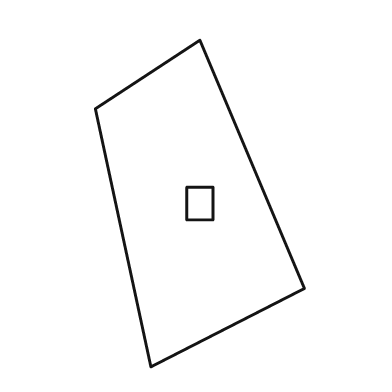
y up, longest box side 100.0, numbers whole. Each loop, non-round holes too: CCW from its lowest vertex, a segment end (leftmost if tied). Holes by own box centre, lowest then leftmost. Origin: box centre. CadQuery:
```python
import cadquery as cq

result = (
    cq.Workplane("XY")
    .moveTo(-15.0, -50.0)
    .lineTo(32.0, -26.0)
    .lineTo(0.0, 50.0)
    .lineTo(-32.0, 29.0)
    .close()
    .moveTo(-4.0, -5.0)
    .lineTo(4.0, -5.0)
    .lineTo(4.0, 5.0)
    .lineTo(-4.0, 5.0)
    .close()
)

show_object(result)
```